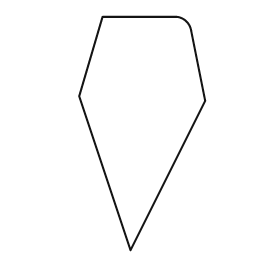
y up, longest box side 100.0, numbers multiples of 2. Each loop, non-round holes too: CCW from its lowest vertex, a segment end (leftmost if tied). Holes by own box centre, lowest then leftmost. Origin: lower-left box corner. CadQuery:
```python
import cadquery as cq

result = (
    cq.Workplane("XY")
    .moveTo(22.0, 0.0)
    .lineTo(54.0, 64.0)
    .lineTo(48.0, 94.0)
    .threePointArc((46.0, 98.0), (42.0, 100.0))
    .lineTo(10.0, 100.0)
    .lineTo(0.0, 66.0)
    .close()
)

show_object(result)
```